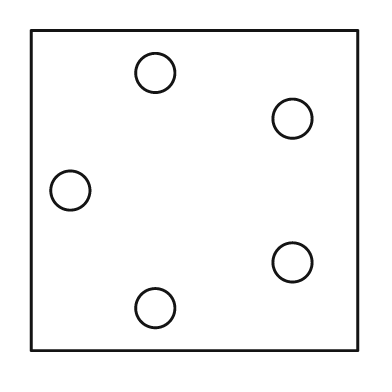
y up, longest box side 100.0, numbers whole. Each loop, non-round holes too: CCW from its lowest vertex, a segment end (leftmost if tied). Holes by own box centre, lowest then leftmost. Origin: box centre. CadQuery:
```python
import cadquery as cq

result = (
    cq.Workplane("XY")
    .moveTo(-50.0, -49.0)
    .lineTo(50.0, -49.0)
    .lineTo(50.0, 49.0)
    .lineTo(-50.0, 49.0)
    .close()
    .moveTo(-12.0, -36.0)
    .circle(6.0)
    .moveTo(30.0, -22.0)
    .circle(6.0)
    .moveTo(-38.0, 0.0)
    .circle(6.0)
    .moveTo(30.0, 22.0)
    .circle(6.0)
    .moveTo(-12.0, 36.0)
    .circle(6.0)
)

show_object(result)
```